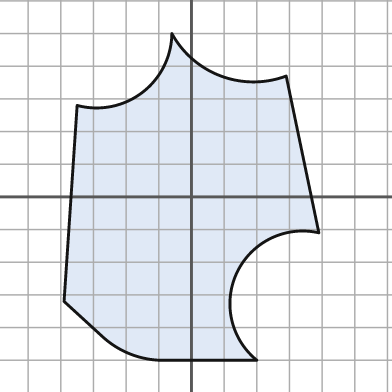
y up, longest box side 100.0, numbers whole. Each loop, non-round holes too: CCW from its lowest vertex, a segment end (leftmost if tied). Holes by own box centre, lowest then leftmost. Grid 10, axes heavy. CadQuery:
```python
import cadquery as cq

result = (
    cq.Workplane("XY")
    .moveTo(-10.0, -50.0)
    .lineTo(20.0, -50.0)
    .threePointArc((14.0, -23.0), (39.0, -11.0))
    .lineTo(29.0, 37.0)
    .threePointArc((9.0, 37.0), (-6.0, 50.0))
    .threePointArc((-15.0, 32.0), (-35.0, 28.0))
    .lineTo(-39.0, -32.0)
    .lineTo(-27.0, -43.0)
    .threePointArc((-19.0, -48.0), (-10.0, -50.0))
    .close()
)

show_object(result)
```